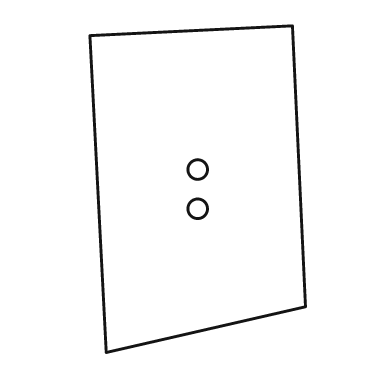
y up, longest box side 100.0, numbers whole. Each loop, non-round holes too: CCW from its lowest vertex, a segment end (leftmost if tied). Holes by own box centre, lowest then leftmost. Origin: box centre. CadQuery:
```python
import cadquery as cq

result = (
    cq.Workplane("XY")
    .moveTo(-28.0, -50.0)
    .lineTo(33.0, -36.0)
    .lineTo(29.0, 50.0)
    .lineTo(-33.0, 47.0)
    .close()
    .moveTo(0.0, -6.0)
    .circle(3.0)
    .moveTo(0.0, 6.0)
    .circle(3.0)
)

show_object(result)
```